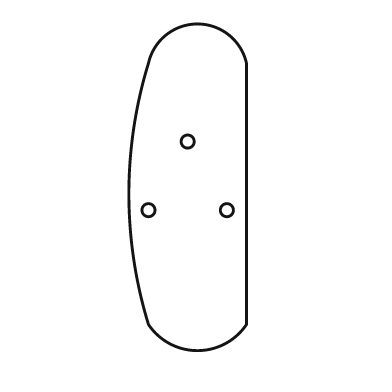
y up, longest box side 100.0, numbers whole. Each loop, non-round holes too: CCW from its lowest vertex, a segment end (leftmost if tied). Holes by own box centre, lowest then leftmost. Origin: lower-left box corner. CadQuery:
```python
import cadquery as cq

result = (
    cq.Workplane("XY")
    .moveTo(6.0, 8.0)
    .threePointArc((21.0, 0.0), (36.0, 8.0))
    .lineTo(36.0, 88.0)
    .threePointArc((21.0, 100.0), (6.0, 88.0))
    .threePointArc((0.0, 48.0), (6.0, 8.0))
    .close()
    .moveTo(6.0, 43.0)
    .circle(2.0)
    .moveTo(30.0, 43.0)
    .circle(2.0)
    .moveTo(18.0, 64.0)
    .circle(2.0)
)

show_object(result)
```